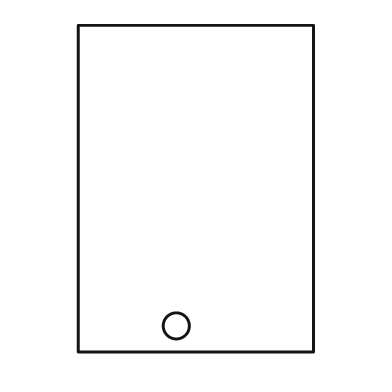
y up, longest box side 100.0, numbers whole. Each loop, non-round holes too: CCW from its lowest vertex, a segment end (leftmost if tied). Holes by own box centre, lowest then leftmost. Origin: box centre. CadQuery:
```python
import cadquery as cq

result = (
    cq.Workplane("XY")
    .moveTo(-36.0, -50.0)
    .lineTo(36.0, -50.0)
    .lineTo(36.0, 50.0)
    .lineTo(-36.0, 50.0)
    .close()
    .moveTo(-6.0, -42.0)
    .circle(4.0)
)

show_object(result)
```